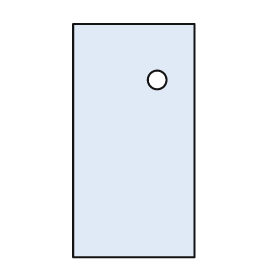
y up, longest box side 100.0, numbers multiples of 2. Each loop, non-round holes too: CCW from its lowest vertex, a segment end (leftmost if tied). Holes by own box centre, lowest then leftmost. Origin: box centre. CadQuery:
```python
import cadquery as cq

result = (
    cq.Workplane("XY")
    .moveTo(-26.0, -50.0)
    .lineTo(26.0, -50.0)
    .lineTo(26.0, 50.0)
    .lineTo(-26.0, 50.0)
    .close()
    .moveTo(10.0, 26.0)
    .circle(4.0)
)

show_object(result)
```